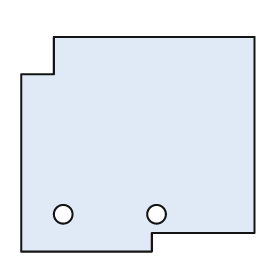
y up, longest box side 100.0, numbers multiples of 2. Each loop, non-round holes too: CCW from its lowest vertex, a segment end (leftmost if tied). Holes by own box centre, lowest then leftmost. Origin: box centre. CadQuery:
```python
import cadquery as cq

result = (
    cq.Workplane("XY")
    .moveTo(-50.0, -46.0)
    .lineTo(6.0, -46.0)
    .lineTo(6.0, -38.0)
    .lineTo(50.0, -38.0)
    .lineTo(50.0, 46.0)
    .lineTo(-36.0, 46.0)
    .lineTo(-36.0, 30.0)
    .lineTo(-50.0, 30.0)
    .close()
    .moveTo(-32.0, -30.0)
    .circle(4.0)
    .moveTo(8.0, -30.0)
    .circle(4.0)
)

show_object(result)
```